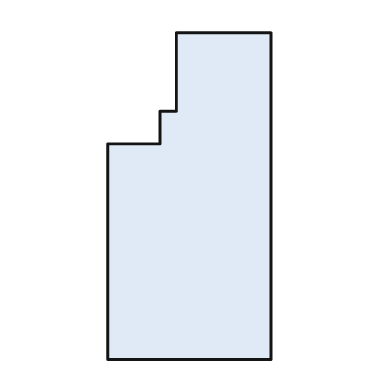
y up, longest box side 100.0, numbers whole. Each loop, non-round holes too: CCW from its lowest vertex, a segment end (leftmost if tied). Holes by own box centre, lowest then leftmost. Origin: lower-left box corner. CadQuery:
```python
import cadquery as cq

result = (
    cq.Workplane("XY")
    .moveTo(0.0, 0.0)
    .lineTo(50.0, 0.0)
    .lineTo(50.0, 100.0)
    .lineTo(21.0, 100.0)
    .lineTo(21.0, 76.0)
    .lineTo(16.0, 76.0)
    .lineTo(16.0, 66.0)
    .lineTo(0.0, 66.0)
    .close()
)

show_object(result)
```